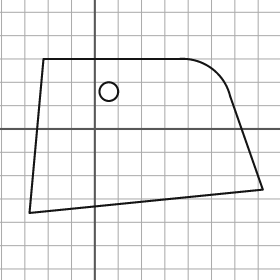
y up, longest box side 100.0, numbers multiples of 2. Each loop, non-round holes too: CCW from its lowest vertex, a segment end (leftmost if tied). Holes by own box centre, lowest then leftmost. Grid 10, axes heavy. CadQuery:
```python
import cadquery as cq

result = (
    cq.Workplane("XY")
    .moveTo(-28.0, -36.0)
    .lineTo(72.0, -26.0)
    .lineTo(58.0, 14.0)
    .threePointArc((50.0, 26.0), (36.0, 30.0))
    .lineTo(-22.0, 30.0)
    .close()
    .moveTo(6.0, 16.0)
    .circle(4.0)
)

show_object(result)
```